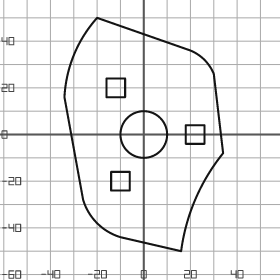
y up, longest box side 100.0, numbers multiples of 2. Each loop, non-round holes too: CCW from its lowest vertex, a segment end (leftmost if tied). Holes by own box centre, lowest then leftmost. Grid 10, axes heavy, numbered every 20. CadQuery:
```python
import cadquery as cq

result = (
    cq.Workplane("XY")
    .moveTo(16.0, -50.0)
    .threePointArc((22.0, -28.0), (34.0, -8.0))
    .lineTo(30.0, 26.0)
    .threePointArc((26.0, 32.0), (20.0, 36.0))
    .lineTo(-20.0, 50.0)
    .threePointArc((-30.0, 34.0), (-34.0, 16.0))
    .lineTo(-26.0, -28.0)
    .threePointArc((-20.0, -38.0), (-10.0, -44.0))
    .close()
    .moveTo(-14.0, -24.0)
    .lineTo(-6.0, -24.0)
    .lineTo(-6.0, -16.0)
    .lineTo(-14.0, -16.0)
    .close()
    .moveTo(0.0, 0.0)
    .circle(10.0)
    .moveTo(18.0, -4.0)
    .lineTo(26.0, -4.0)
    .lineTo(26.0, 4.0)
    .lineTo(18.0, 4.0)
    .close()
    .moveTo(-16.0, 16.0)
    .lineTo(-8.0, 16.0)
    .lineTo(-8.0, 24.0)
    .lineTo(-16.0, 24.0)
    .close()
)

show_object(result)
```